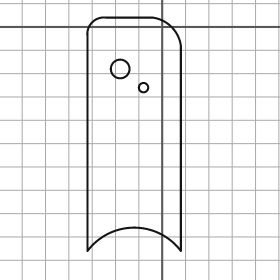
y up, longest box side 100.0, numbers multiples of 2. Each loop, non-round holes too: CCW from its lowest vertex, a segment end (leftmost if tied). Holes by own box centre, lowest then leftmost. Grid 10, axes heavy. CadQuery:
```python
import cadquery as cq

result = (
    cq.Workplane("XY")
    .moveTo(-32.0, -96.0)
    .threePointArc((-12.0, -86.0), (8.0, -96.0))
    .lineTo(8.0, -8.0)
    .threePointArc((4.0, 0.0), (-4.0, 4.0))
    .lineTo(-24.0, 4.0)
    .threePointArc((-30.0, 2.0), (-32.0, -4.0))
    .close()
    .moveTo(-8.0, -26.0)
    .circle(2.0)
    .moveTo(-18.0, -18.0)
    .circle(4.0)
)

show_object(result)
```